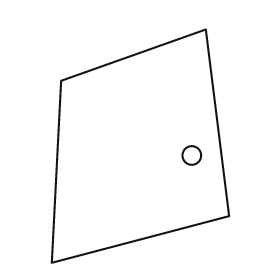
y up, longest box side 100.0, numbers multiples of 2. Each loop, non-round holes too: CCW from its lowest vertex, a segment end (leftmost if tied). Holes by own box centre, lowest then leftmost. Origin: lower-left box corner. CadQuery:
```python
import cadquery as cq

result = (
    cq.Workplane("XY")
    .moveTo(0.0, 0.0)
    .lineTo(76.0, 20.0)
    .lineTo(66.0, 100.0)
    .lineTo(4.0, 78.0)
    .close()
    .moveTo(60.0, 46.0)
    .circle(4.0)
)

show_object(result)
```